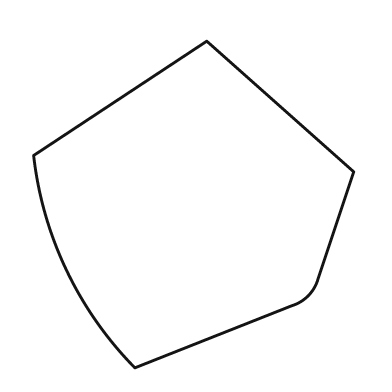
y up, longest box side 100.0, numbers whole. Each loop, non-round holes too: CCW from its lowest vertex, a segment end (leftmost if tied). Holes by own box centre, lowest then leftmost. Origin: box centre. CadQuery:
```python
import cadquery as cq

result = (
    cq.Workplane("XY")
    .moveTo(-18.0, -50.0)
    .lineTo(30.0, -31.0)
    .threePointArc((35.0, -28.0), (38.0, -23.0))
    .lineTo(49.0, 10.0)
    .lineTo(4.0, 50.0)
    .lineTo(-49.0, 15.0)
    .threePointArc((-39.0, -20.0), (-18.0, -50.0))
    .close()
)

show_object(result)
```